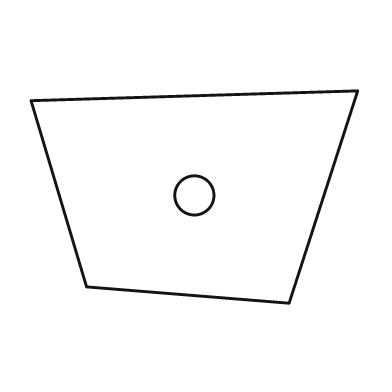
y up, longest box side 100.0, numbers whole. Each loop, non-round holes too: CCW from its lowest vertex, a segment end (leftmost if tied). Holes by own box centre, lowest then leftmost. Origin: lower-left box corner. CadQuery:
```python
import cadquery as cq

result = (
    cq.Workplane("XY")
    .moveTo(79.0, 0.0)
    .lineTo(100.0, 65.0)
    .lineTo(0.0, 62.0)
    .lineTo(17.0, 5.0)
    .close()
    .moveTo(50.0, 33.0)
    .circle(6.0)
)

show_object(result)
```